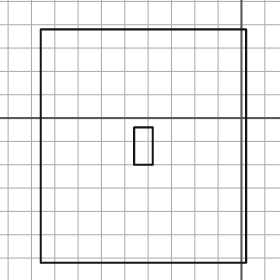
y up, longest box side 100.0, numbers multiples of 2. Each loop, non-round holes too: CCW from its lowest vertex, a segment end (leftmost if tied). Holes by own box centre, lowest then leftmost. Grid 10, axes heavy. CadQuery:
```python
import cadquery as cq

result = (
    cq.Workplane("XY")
    .moveTo(-86.0, -62.0)
    .lineTo(2.0, -62.0)
    .lineTo(2.0, 38.0)
    .lineTo(-86.0, 38.0)
    .close()
    .moveTo(-46.0, -20.0)
    .lineTo(-38.0, -20.0)
    .lineTo(-38.0, -4.0)
    .lineTo(-46.0, -4.0)
    .close()
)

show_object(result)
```